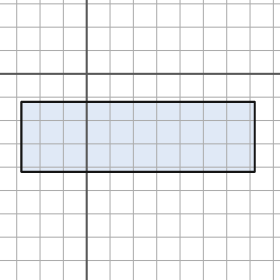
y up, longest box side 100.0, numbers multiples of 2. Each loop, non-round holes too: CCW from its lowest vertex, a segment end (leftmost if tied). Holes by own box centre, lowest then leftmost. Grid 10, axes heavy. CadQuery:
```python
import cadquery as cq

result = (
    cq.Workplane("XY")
    .moveTo(-28.0, -42.0)
    .lineTo(72.0, -42.0)
    .lineTo(72.0, -12.0)
    .lineTo(-28.0, -12.0)
    .close()
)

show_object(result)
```